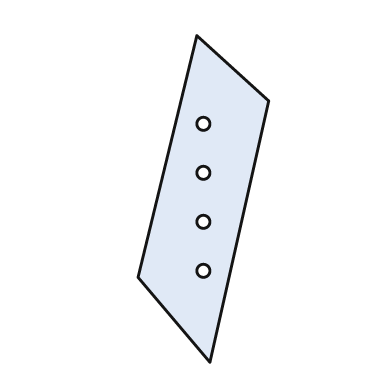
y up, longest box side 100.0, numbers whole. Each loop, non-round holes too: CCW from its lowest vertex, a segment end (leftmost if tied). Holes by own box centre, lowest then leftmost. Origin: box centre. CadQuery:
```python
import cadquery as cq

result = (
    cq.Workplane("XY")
    .moveTo(2.0, -50.0)
    .lineTo(20.0, 30.0)
    .lineTo(-2.0, 50.0)
    .lineTo(-20.0, -24.0)
    .close()
    .moveTo(0.0, -22.0)
    .circle(2.0)
    .moveTo(0.0, -7.0)
    .circle(2.0)
    .moveTo(0.0, 8.0)
    .circle(2.0)
    .moveTo(0.0, 23.0)
    .circle(2.0)
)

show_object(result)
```